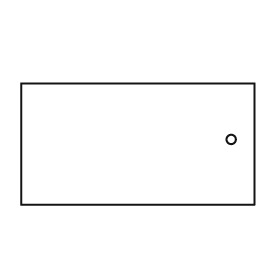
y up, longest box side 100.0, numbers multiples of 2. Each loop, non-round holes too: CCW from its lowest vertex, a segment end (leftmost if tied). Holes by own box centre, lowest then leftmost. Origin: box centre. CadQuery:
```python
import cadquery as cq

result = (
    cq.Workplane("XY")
    .moveTo(-50.0, -26.0)
    .lineTo(50.0, -26.0)
    .lineTo(50.0, 26.0)
    .lineTo(-50.0, 26.0)
    .close()
    .moveTo(40.0, 2.0)
    .circle(2.0)
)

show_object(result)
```